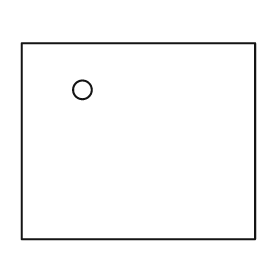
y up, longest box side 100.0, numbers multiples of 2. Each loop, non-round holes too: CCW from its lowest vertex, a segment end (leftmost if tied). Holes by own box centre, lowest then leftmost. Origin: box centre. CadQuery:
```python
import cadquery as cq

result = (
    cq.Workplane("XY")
    .moveTo(-50.0, -42.0)
    .lineTo(50.0, -42.0)
    .lineTo(50.0, 42.0)
    .lineTo(-50.0, 42.0)
    .close()
    .moveTo(-24.0, 22.0)
    .circle(4.0)
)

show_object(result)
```